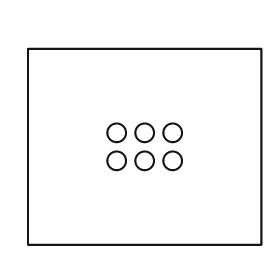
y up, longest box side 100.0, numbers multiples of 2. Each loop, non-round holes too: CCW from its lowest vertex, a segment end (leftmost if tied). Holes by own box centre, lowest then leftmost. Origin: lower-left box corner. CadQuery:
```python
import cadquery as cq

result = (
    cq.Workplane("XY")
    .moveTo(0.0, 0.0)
    .lineTo(100.0, 0.0)
    .lineTo(100.0, 84.0)
    .lineTo(0.0, 84.0)
    .close()
    .moveTo(38.0, 36.0)
    .circle(4.0)
    .moveTo(50.0, 36.0)
    .circle(4.0)
    .moveTo(62.0, 36.0)
    .circle(4.0)
    .moveTo(38.0, 48.0)
    .circle(4.0)
    .moveTo(50.0, 48.0)
    .circle(4.0)
    .moveTo(62.0, 48.0)
    .circle(4.0)
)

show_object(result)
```